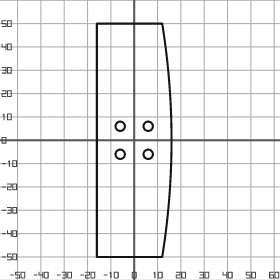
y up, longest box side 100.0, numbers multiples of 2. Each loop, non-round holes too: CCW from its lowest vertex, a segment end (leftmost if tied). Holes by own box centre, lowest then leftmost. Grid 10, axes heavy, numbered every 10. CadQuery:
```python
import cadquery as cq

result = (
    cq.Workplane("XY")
    .moveTo(-16.0, -50.0)
    .lineTo(12.0, -50.0)
    .threePointArc((16.0, 0.0), (12.0, 50.0))
    .lineTo(-16.0, 50.0)
    .close()
    .moveTo(-6.0, -6.0)
    .circle(2.0)
    .moveTo(6.0, -6.0)
    .circle(2.0)
    .moveTo(-6.0, 6.0)
    .circle(2.0)
    .moveTo(6.0, 6.0)
    .circle(2.0)
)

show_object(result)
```